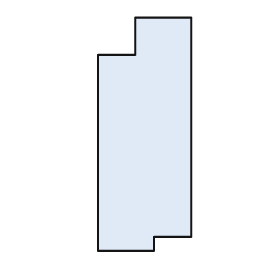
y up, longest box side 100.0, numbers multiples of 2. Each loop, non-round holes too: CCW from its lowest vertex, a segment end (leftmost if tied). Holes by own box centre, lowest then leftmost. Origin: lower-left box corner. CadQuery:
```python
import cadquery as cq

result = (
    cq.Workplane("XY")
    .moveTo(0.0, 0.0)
    .lineTo(24.0, 0.0)
    .lineTo(24.0, 6.0)
    .lineTo(40.0, 6.0)
    .lineTo(40.0, 100.0)
    .lineTo(16.0, 100.0)
    .lineTo(16.0, 84.0)
    .lineTo(0.0, 84.0)
    .close()
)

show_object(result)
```